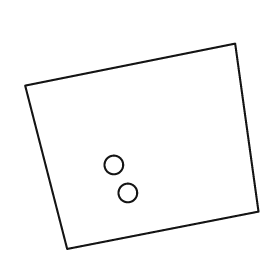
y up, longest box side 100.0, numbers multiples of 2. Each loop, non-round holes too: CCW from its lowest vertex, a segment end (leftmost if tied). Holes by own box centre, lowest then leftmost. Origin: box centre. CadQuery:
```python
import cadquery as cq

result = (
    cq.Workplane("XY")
    .moveTo(-32.0, -44.0)
    .lineTo(50.0, -28.0)
    .lineTo(40.0, 44.0)
    .lineTo(-50.0, 26.0)
    .close()
    .moveTo(-6.0, -20.0)
    .circle(4.0)
    .moveTo(-12.0, -8.0)
    .circle(4.0)
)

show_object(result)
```